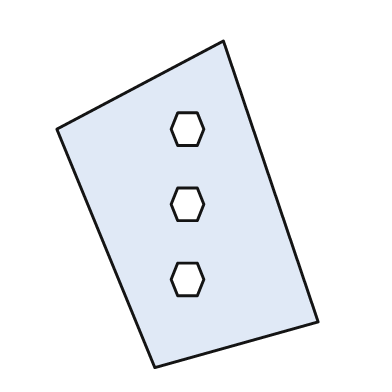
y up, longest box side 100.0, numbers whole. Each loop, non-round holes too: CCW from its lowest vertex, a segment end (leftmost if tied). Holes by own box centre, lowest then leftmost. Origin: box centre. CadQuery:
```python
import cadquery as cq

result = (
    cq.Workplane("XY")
    .moveTo(-10.0, -50.0)
    .lineTo(40.0, -36.0)
    .lineTo(11.0, 50.0)
    .lineTo(-40.0, 23.0)
    .close()
    .moveTo(-3.0, -28.0)
    .lineTo(3.0, -28.0)
    .lineTo(5.0, -23.0)
    .lineTo(3.0, -18.0)
    .lineTo(-3.0, -18.0)
    .lineTo(-5.0, -23.0)
    .close()
    .moveTo(-3.0, -5.0)
    .lineTo(3.0, -5.0)
    .lineTo(5.0, 0.0)
    .lineTo(3.0, 5.0)
    .lineTo(-3.0, 5.0)
    .lineTo(-5.0, 0.0)
    .close()
    .moveTo(-3.0, 18.0)
    .lineTo(3.0, 18.0)
    .lineTo(5.0, 23.0)
    .lineTo(3.0, 28.0)
    .lineTo(-3.0, 28.0)
    .lineTo(-5.0, 23.0)
    .close()
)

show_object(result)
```